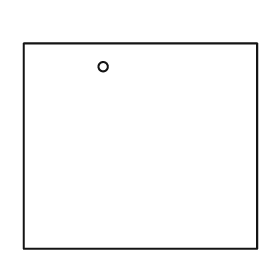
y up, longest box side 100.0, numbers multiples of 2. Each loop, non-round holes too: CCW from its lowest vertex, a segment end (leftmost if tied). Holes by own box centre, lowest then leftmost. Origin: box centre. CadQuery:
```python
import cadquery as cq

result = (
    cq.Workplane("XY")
    .moveTo(-50.0, -44.0)
    .lineTo(50.0, -44.0)
    .lineTo(50.0, 44.0)
    .lineTo(-50.0, 44.0)
    .close()
    .moveTo(-16.0, 34.0)
    .circle(2.0)
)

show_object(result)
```